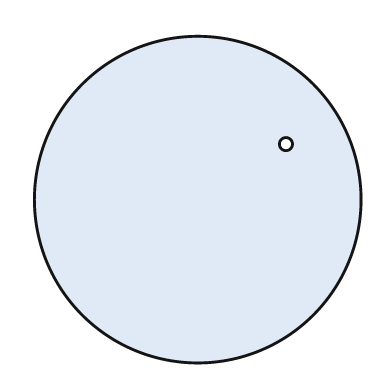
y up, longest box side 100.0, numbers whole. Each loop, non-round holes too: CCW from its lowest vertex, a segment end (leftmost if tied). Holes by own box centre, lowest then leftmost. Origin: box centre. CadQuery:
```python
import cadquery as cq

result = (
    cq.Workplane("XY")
    .moveTo(0.0, 0.0)
    .circle(50.0)
    .moveTo(27.0, 17.0)
    .circle(2.0)
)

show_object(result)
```